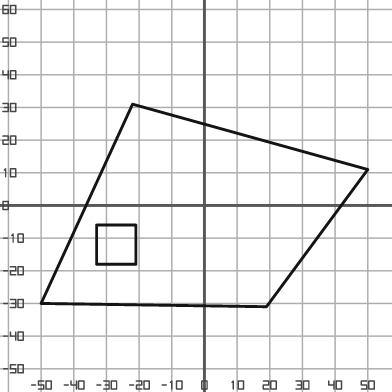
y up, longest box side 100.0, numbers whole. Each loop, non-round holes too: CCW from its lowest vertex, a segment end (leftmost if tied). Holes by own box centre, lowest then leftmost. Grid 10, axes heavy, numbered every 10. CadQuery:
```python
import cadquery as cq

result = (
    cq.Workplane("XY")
    .moveTo(19.0, -31.0)
    .lineTo(50.0, 11.0)
    .lineTo(-22.0, 31.0)
    .lineTo(-50.0, -30.0)
    .close()
    .moveTo(-33.0, -18.0)
    .lineTo(-21.0, -18.0)
    .lineTo(-21.0, -6.0)
    .lineTo(-33.0, -6.0)
    .close()
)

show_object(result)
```